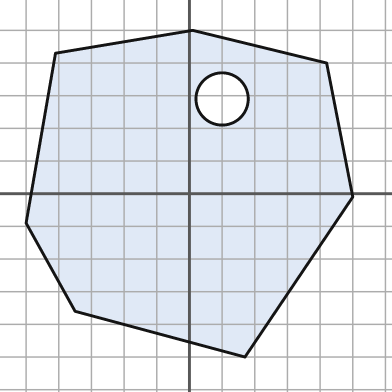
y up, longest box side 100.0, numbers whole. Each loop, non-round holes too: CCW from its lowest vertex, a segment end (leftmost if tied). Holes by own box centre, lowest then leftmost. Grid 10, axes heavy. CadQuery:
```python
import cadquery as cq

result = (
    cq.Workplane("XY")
    .moveTo(17.0, -50.0)
    .lineTo(50.0, -1.0)
    .lineTo(42.0, 40.0)
    .lineTo(1.0, 50.0)
    .lineTo(-41.0, 43.0)
    .lineTo(-50.0, -9.0)
    .lineTo(-35.0, -36.0)
    .close()
    .moveTo(10.0, 29.0)
    .circle(8.0)
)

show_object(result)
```